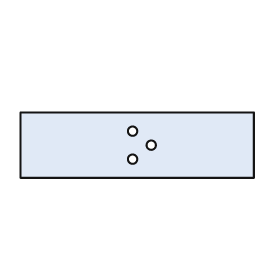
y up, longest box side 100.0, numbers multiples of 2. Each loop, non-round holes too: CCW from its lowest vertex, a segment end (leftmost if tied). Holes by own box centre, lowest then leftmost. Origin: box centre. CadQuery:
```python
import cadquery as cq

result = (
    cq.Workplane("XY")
    .moveTo(-50.0, -14.0)
    .lineTo(50.0, -14.0)
    .lineTo(50.0, 14.0)
    .lineTo(-50.0, 14.0)
    .close()
    .moveTo(-2.0, -6.0)
    .circle(2.0)
    .moveTo(6.0, 0.0)
    .circle(2.0)
    .moveTo(-2.0, 6.0)
    .circle(2.0)
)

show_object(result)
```